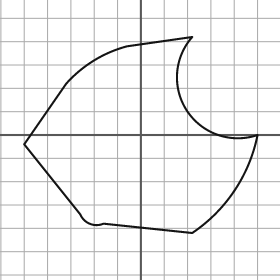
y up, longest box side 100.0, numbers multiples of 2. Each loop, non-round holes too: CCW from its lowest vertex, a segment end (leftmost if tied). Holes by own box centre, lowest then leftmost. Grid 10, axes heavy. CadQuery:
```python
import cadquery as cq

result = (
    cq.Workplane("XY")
    .moveTo(22.0, -42.0)
    .threePointArc((40.0, -24.0), (50.0, 0.0))
    .threePointArc((20.0, 10.0), (22.0, 42.0))
    .lineTo(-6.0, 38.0)
    .threePointArc((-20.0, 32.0), (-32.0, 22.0))
    .lineTo(-50.0, -4.0)
    .lineTo(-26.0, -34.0)
    .threePointArc((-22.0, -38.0), (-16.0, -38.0))
    .close()
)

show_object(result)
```